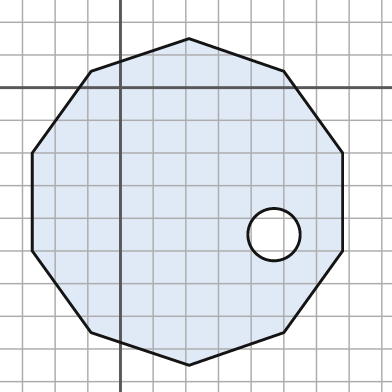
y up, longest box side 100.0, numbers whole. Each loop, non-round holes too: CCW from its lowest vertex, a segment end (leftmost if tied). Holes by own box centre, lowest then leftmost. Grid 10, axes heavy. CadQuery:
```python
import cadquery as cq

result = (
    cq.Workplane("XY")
    .moveTo(21.0, -85.0)
    .lineTo(50.0, -75.0)
    .lineTo(68.0, -50.0)
    .lineTo(68.0, -20.0)
    .lineTo(50.0, 5.0)
    .lineTo(21.0, 15.0)
    .lineTo(-9.0, 5.0)
    .lineTo(-27.0, -20.0)
    .lineTo(-27.0, -50.0)
    .lineTo(-9.0, -75.0)
    .close()
    .moveTo(47.0, -45.0)
    .circle(8.0)
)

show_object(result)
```